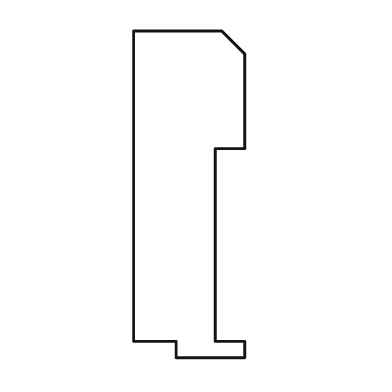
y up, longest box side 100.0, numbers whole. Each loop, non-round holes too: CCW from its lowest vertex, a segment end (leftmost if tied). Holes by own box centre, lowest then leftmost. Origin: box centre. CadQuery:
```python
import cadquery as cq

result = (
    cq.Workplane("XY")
    .moveTo(-4.0, -50.0)
    .lineTo(17.0, -50.0)
    .lineTo(17.0, -45.0)
    .lineTo(8.0, -45.0)
    .lineTo(8.0, 14.0)
    .lineTo(17.0, 14.0)
    .lineTo(17.0, 43.0)
    .lineTo(10.0, 50.0)
    .lineTo(-17.0, 50.0)
    .lineTo(-17.0, -45.0)
    .lineTo(-4.0, -45.0)
    .close()
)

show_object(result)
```